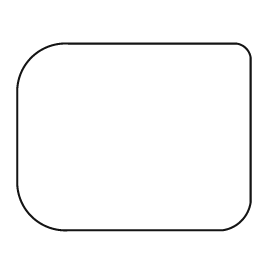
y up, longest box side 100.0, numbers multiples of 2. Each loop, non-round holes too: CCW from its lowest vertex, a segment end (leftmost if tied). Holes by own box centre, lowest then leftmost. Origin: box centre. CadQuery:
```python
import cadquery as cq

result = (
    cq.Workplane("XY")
    .moveTo(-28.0, -40.0)
    .lineTo(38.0, -40.0)
    .threePointArc((46.0, -36.0), (50.0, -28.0))
    .lineTo(50.0, 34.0)
    .threePointArc((48.0, 38.0), (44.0, 40.0))
    .lineTo(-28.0, 40.0)
    .threePointArc((-44.0, 34.0), (-50.0, 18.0))
    .lineTo(-50.0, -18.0)
    .threePointArc((-44.0, -34.0), (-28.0, -40.0))
    .close()
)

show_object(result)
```